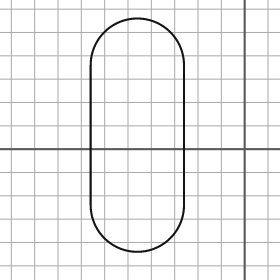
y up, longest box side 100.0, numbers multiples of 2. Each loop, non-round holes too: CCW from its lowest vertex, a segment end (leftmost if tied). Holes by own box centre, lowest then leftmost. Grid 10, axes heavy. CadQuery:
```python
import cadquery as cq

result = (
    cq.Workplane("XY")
    .moveTo(-66.0, -24.0)
    .threePointArc((-46.0, -44.0), (-26.0, -24.0))
    .lineTo(-26.0, 36.0)
    .threePointArc((-46.0, 56.0), (-66.0, 36.0))
    .close()
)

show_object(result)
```